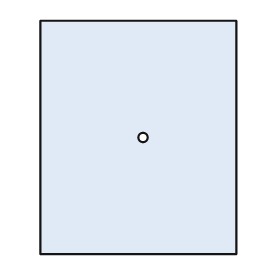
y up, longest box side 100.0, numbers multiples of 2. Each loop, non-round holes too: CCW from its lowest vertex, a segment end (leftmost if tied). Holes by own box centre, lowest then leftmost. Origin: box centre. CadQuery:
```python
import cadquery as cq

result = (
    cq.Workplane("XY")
    .moveTo(-42.0, -50.0)
    .lineTo(42.0, -50.0)
    .lineTo(42.0, 50.0)
    .lineTo(-42.0, 50.0)
    .close()
    .moveTo(2.0, 0.0)
    .circle(2.0)
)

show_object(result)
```